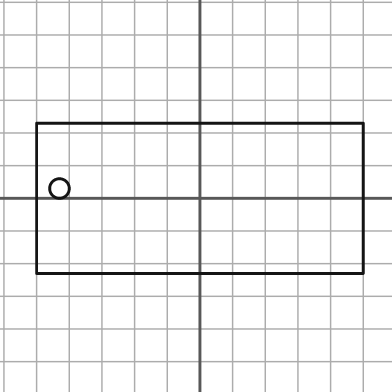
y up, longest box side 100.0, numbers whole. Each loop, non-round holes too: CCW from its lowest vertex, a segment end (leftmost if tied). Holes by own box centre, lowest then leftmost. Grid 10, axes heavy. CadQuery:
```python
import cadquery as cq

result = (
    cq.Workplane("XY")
    .moveTo(-50.0, -23.0)
    .lineTo(50.0, -23.0)
    .lineTo(50.0, 23.0)
    .lineTo(-50.0, 23.0)
    .close()
    .moveTo(-43.0, 3.0)
    .circle(3.0)
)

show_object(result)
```